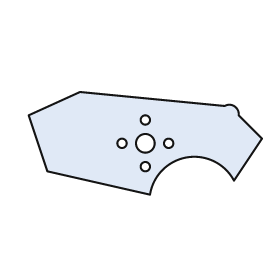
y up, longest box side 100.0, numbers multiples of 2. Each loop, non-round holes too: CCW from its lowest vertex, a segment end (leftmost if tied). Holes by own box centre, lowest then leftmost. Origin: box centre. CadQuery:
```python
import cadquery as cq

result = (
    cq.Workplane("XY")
    .moveTo(2.0, -22.0)
    .threePointArc((18.0, -6.0), (38.0, -16.0))
    .lineTo(50.0, 2.0)
    .lineTo(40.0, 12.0)
    .threePointArc((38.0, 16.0), (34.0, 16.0))
    .lineTo(-28.0, 22.0)
    .lineTo(-50.0, 12.0)
    .lineTo(-42.0, -12.0)
    .close()
    .moveTo(0.0, -10.0)
    .circle(2.0)
    .moveTo(-10.0, 0.0)
    .circle(2.0)
    .moveTo(0.0, 0.0)
    .circle(4.0)
    .moveTo(10.0, 0.0)
    .circle(2.0)
    .moveTo(0.0, 10.0)
    .circle(2.0)
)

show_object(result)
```